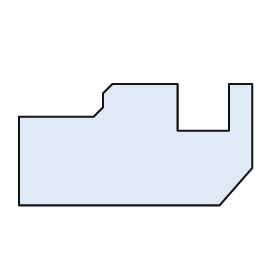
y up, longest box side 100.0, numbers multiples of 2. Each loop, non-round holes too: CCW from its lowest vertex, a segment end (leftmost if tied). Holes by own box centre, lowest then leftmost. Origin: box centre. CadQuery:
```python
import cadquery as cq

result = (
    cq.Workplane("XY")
    .moveTo(-50.0, -26.0)
    .lineTo(36.0, -26.0)
    .lineTo(50.0, -10.0)
    .lineTo(50.0, 26.0)
    .lineTo(40.0, 26.0)
    .lineTo(40.0, 6.0)
    .lineTo(18.0, 6.0)
    .lineTo(18.0, 26.0)
    .lineTo(-10.0, 26.0)
    .lineTo(-14.0, 22.0)
    .lineTo(-14.0, 16.0)
    .lineTo(-18.0, 12.0)
    .lineTo(-50.0, 12.0)
    .close()
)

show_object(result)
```